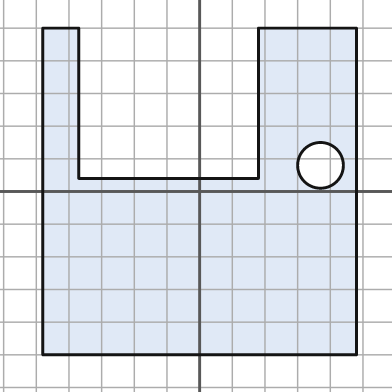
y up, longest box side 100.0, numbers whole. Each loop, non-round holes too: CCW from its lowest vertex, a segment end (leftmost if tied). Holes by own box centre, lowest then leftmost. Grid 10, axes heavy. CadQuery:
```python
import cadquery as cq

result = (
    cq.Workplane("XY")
    .moveTo(-48.0, -50.0)
    .lineTo(48.0, -50.0)
    .lineTo(48.0, 50.0)
    .lineTo(18.0, 50.0)
    .lineTo(18.0, 4.0)
    .lineTo(-37.0, 4.0)
    .lineTo(-37.0, 50.0)
    .lineTo(-48.0, 50.0)
    .close()
    .moveTo(37.0, 8.0)
    .circle(7.0)
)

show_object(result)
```